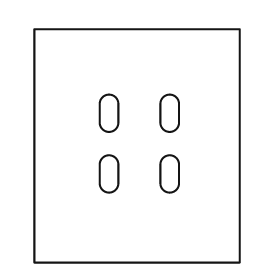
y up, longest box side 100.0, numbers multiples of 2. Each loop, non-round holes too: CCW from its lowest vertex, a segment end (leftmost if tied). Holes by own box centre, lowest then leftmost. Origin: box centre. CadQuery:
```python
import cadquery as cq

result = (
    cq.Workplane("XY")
    .moveTo(-44.0, -50.0)
    .lineTo(44.0, -50.0)
    .lineTo(44.0, 50.0)
    .lineTo(-44.0, 50.0)
    .close()
    .moveTo(-16.0, -16.0)
    .threePointArc((-12.0, -20.0), (-8.0, -16.0))
    .lineTo(-8.0, -8.0)
    .threePointArc((-12.0, -4.0), (-16.0, -8.0))
    .close()
    .moveTo(10.0, -16.0)
    .threePointArc((14.0, -20.0), (18.0, -16.0))
    .lineTo(18.0, -8.0)
    .threePointArc((14.0, -4.0), (10.0, -8.0))
    .close()
    .moveTo(-16.0, 10.0)
    .threePointArc((-12.0, 6.0), (-8.0, 10.0))
    .lineTo(-8.0, 18.0)
    .threePointArc((-12.0, 22.0), (-16.0, 18.0))
    .close()
    .moveTo(10.0, 10.0)
    .threePointArc((14.0, 6.0), (18.0, 10.0))
    .lineTo(18.0, 18.0)
    .threePointArc((14.0, 22.0), (10.0, 18.0))
    .close()
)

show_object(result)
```